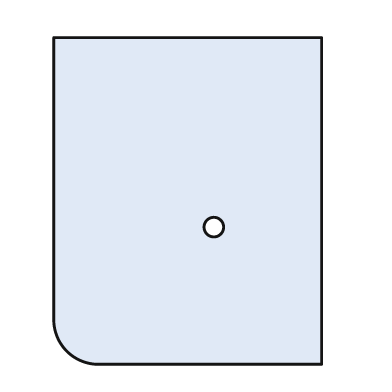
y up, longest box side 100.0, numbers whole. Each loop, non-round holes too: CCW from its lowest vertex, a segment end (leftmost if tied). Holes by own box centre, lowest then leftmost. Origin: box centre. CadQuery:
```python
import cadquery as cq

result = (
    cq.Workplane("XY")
    .moveTo(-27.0, -50.0)
    .lineTo(41.0, -50.0)
    .lineTo(41.0, 50.0)
    .lineTo(-41.0, 50.0)
    .lineTo(-41.0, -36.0)
    .threePointArc((-37.0, -46.0), (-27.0, -50.0))
    .close()
    .moveTo(8.0, -8.0)
    .circle(3.0)
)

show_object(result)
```